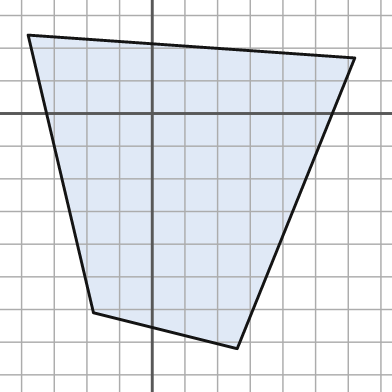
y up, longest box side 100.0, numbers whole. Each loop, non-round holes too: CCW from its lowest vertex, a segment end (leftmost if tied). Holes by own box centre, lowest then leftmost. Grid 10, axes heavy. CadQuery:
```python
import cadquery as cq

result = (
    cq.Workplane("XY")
    .moveTo(26.0, -72.0)
    .lineTo(62.0, 17.0)
    .lineTo(-38.0, 24.0)
    .lineTo(-18.0, -61.0)
    .close()
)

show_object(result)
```